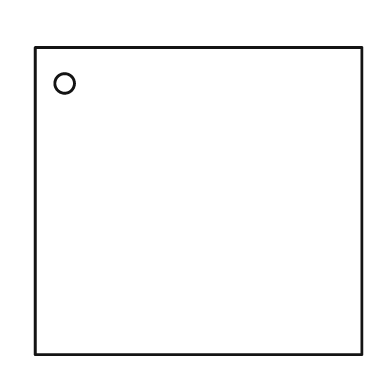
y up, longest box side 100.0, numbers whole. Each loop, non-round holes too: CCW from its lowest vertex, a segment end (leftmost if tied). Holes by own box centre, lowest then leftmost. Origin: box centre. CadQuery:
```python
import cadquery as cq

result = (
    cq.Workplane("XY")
    .moveTo(-50.0, -47.0)
    .lineTo(50.0, -47.0)
    .lineTo(50.0, 47.0)
    .lineTo(-50.0, 47.0)
    .close()
    .moveTo(-41.0, 36.0)
    .circle(3.0)
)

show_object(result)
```